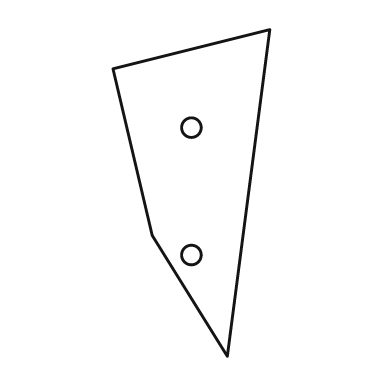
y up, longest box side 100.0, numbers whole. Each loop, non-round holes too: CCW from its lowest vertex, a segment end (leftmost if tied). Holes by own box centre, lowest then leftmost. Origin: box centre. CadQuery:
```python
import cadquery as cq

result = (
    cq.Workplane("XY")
    .moveTo(11.0, -50.0)
    .lineTo(24.0, 50.0)
    .lineTo(-24.0, 38.0)
    .lineTo(-12.0, -13.0)
    .close()
    .moveTo(0.0, -19.0)
    .circle(3.0)
    .moveTo(0.0, 20.0)
    .circle(3.0)
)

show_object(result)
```